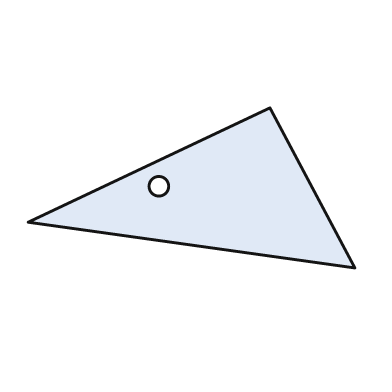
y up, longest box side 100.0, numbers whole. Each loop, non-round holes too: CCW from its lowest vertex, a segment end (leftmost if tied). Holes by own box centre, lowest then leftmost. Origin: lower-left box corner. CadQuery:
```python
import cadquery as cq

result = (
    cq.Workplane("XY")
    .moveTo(100.0, 0.0)
    .lineTo(74.0, 49.0)
    .lineTo(0.0, 14.0)
    .close()
    .moveTo(40.0, 25.0)
    .circle(3.0)
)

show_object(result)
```